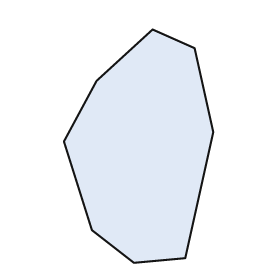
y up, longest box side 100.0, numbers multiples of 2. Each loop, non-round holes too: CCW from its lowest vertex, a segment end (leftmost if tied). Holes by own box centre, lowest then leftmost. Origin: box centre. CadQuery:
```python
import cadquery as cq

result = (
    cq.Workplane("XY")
    .moveTo(-2.0, -50.0)
    .lineTo(20.0, -48.0)
    .lineTo(32.0, 6.0)
    .lineTo(24.0, 42.0)
    .lineTo(6.0, 50.0)
    .lineTo(-18.0, 28.0)
    .lineTo(-32.0, 2.0)
    .lineTo(-20.0, -36.0)
    .close()
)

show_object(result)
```